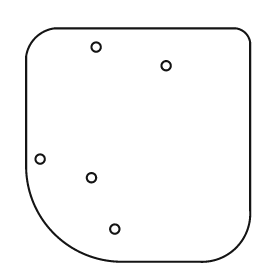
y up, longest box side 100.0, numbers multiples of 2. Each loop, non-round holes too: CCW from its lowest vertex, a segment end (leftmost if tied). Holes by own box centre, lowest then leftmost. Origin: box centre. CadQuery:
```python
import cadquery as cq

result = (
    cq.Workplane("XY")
    .moveTo(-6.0, -50.0)
    .lineTo(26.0, -50.0)
    .threePointArc((42.0, -44.0), (48.0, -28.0))
    .lineTo(48.0, 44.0)
    .threePointArc((46.0, 48.0), (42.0, 50.0))
    .lineTo(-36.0, 50.0)
    .threePointArc((-44.0, 46.0), (-48.0, 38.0))
    .lineTo(-48.0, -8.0)
    .threePointArc((-36.0, -38.0), (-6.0, -50.0))
    .close()
    .moveTo(-10.0, -36.0)
    .circle(2.0)
    .moveTo(-20.0, -14.0)
    .circle(2.0)
    .moveTo(-42.0, -6.0)
    .circle(2.0)
    .moveTo(12.0, 34.0)
    .circle(2.0)
    .moveTo(-18.0, 42.0)
    .circle(2.0)
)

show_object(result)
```